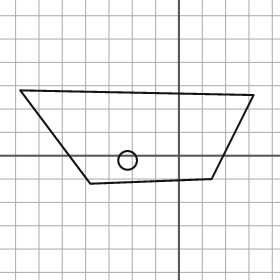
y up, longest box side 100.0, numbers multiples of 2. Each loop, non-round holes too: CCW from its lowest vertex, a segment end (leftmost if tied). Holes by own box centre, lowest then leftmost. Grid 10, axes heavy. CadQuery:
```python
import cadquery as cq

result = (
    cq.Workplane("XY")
    .moveTo(-38.0, -12.0)
    .lineTo(14.0, -10.0)
    .lineTo(32.0, 26.0)
    .lineTo(-68.0, 28.0)
    .close()
    .moveTo(-22.0, -2.0)
    .circle(4.0)
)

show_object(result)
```